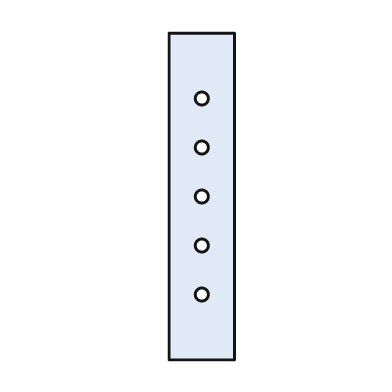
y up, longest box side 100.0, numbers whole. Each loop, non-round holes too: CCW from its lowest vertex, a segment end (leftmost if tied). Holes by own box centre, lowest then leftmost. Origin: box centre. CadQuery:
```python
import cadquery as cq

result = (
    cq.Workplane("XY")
    .moveTo(-10.0, -50.0)
    .lineTo(10.0, -50.0)
    .lineTo(10.0, 50.0)
    .lineTo(-10.0, 50.0)
    .close()
    .moveTo(0.0, -30.0)
    .circle(2.0)
    .moveTo(0.0, -15.0)
    .circle(2.0)
    .moveTo(0.0, 0.0)
    .circle(2.0)
    .moveTo(0.0, 15.0)
    .circle(2.0)
    .moveTo(0.0, 30.0)
    .circle(2.0)
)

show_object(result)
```